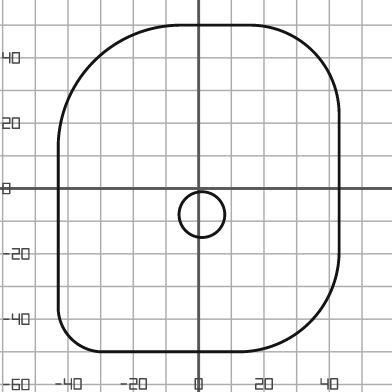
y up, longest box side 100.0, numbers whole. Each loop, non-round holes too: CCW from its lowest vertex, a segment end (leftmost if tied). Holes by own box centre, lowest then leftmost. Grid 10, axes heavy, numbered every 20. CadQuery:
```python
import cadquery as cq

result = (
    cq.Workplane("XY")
    .moveTo(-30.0, -50.0)
    .lineTo(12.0, -50.0)
    .threePointArc((34.0, -41.0), (43.0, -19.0))
    .lineTo(43.0, 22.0)
    .threePointArc((35.0, 42.0), (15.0, 50.0))
    .lineTo(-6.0, 50.0)
    .threePointArc((-32.0, 39.0), (-43.0, 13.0))
    .lineTo(-43.0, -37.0)
    .threePointArc((-39.0, -46.0), (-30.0, -50.0))
    .close()
    .moveTo(1.0, -8.0)
    .circle(7.0)
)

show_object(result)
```